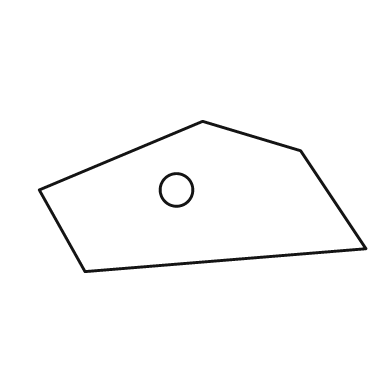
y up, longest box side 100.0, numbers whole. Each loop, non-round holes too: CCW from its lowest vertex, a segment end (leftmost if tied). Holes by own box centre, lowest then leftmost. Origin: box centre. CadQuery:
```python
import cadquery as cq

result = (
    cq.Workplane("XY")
    .moveTo(-36.0, -23.0)
    .lineTo(50.0, -16.0)
    .lineTo(30.0, 14.0)
    .lineTo(0.0, 23.0)
    .lineTo(-50.0, 2.0)
    .close()
    .moveTo(-8.0, 2.0)
    .circle(5.0)
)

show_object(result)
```